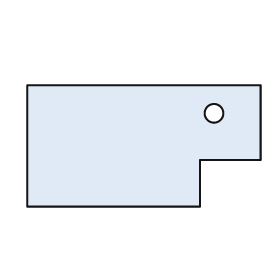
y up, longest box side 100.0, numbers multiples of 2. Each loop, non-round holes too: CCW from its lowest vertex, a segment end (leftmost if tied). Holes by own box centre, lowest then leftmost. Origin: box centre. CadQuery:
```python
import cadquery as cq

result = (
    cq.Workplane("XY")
    .moveTo(-50.0, -26.0)
    .lineTo(24.0, -26.0)
    .lineTo(24.0, -6.0)
    .lineTo(50.0, -6.0)
    .lineTo(50.0, 26.0)
    .lineTo(-50.0, 26.0)
    .close()
    .moveTo(30.0, 14.0)
    .circle(4.0)
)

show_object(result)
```